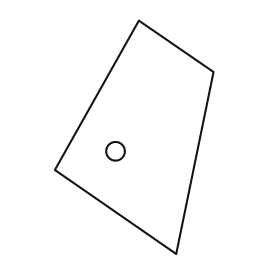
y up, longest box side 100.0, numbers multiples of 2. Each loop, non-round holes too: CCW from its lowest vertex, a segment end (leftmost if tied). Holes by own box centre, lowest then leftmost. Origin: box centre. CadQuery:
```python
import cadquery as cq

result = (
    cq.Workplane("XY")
    .moveTo(18.0, -50.0)
    .lineTo(34.0, 28.0)
    .lineTo(2.0, 50.0)
    .lineTo(-34.0, -14.0)
    .close()
    .moveTo(-8.0, -6.0)
    .circle(4.0)
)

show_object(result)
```